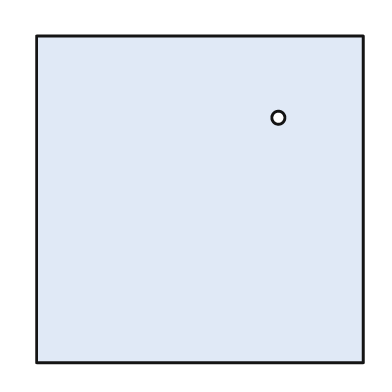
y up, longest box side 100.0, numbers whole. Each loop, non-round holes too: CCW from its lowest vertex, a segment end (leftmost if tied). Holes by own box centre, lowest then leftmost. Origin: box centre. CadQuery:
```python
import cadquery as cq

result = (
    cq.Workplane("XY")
    .moveTo(-50.0, -50.0)
    .lineTo(50.0, -50.0)
    .lineTo(50.0, 50.0)
    .lineTo(-50.0, 50.0)
    .close()
    .moveTo(24.0, 25.0)
    .circle(2.0)
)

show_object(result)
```